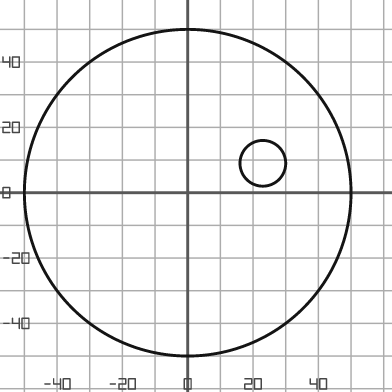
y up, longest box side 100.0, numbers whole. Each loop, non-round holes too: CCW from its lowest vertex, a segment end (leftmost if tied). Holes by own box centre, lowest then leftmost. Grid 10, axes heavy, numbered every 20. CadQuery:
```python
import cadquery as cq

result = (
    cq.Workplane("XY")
    .moveTo(0.0, 0.0)
    .circle(50.0)
    .moveTo(23.0, 9.0)
    .circle(7.0)
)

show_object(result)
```